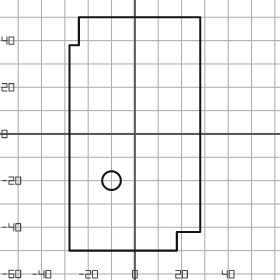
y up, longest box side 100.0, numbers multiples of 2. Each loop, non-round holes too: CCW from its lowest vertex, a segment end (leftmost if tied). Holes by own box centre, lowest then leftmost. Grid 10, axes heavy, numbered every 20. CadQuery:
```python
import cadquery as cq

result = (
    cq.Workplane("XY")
    .moveTo(-28.0, -50.0)
    .lineTo(18.0, -50.0)
    .lineTo(18.0, -42.0)
    .lineTo(28.0, -42.0)
    .lineTo(28.0, 50.0)
    .lineTo(-24.0, 50.0)
    .lineTo(-24.0, 38.0)
    .lineTo(-28.0, 38.0)
    .close()
    .moveTo(-10.0, -20.0)
    .circle(4.0)
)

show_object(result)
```